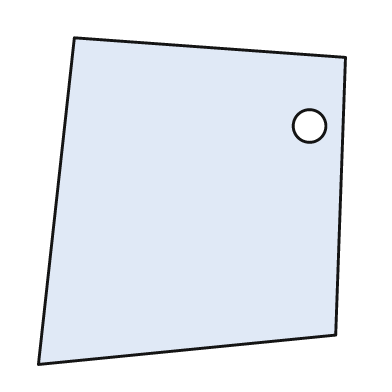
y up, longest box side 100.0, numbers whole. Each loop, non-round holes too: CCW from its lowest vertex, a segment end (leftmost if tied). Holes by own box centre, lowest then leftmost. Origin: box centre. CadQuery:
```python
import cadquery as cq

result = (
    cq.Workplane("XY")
    .moveTo(-47.0, -50.0)
    .lineTo(44.0, -41.0)
    .lineTo(47.0, 44.0)
    .lineTo(-36.0, 50.0)
    .close()
    .moveTo(36.0, 23.0)
    .circle(5.0)
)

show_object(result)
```